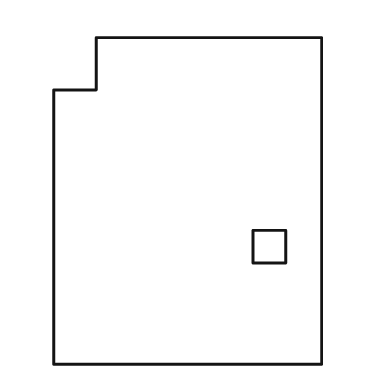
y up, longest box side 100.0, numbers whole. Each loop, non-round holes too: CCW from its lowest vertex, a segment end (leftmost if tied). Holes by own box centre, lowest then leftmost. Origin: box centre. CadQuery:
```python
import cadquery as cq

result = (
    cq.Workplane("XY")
    .moveTo(-41.0, -50.0)
    .lineTo(41.0, -50.0)
    .lineTo(41.0, 50.0)
    .lineTo(-28.0, 50.0)
    .lineTo(-28.0, 34.0)
    .lineTo(-41.0, 34.0)
    .close()
    .moveTo(20.0, -19.0)
    .lineTo(30.0, -19.0)
    .lineTo(30.0, -9.0)
    .lineTo(20.0, -9.0)
    .close()
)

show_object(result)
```